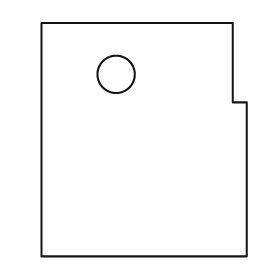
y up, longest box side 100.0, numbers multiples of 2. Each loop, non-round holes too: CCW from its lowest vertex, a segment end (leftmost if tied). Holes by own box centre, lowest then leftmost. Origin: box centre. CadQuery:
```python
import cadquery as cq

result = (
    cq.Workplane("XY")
    .moveTo(-44.0, -50.0)
    .lineTo(44.0, -50.0)
    .lineTo(44.0, 16.0)
    .lineTo(38.0, 16.0)
    .lineTo(38.0, 50.0)
    .lineTo(-44.0, 50.0)
    .close()
    .moveTo(-12.0, 28.0)
    .circle(8.0)
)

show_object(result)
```